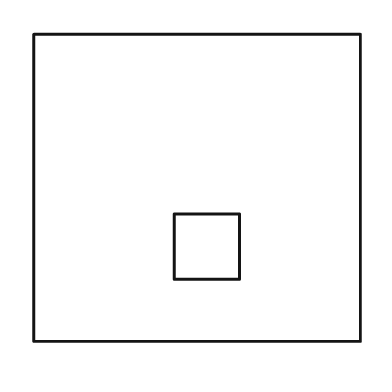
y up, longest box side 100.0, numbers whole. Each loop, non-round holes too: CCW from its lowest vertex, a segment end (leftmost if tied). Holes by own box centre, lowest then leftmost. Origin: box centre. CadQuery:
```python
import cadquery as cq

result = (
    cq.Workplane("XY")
    .moveTo(-50.0, -47.0)
    .lineTo(50.0, -47.0)
    .lineTo(50.0, 47.0)
    .lineTo(-50.0, 47.0)
    .close()
    .moveTo(-7.0, -28.0)
    .lineTo(13.0, -28.0)
    .lineTo(13.0, -8.0)
    .lineTo(-7.0, -8.0)
    .close()
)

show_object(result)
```